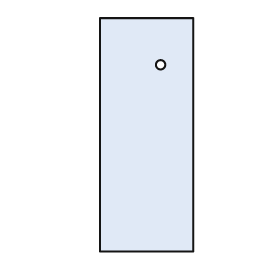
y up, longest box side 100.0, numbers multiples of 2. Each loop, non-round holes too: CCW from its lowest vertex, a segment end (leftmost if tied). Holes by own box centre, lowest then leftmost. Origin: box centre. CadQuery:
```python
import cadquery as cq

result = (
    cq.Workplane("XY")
    .moveTo(-20.0, -50.0)
    .lineTo(20.0, -50.0)
    .lineTo(20.0, 50.0)
    .lineTo(-20.0, 50.0)
    .close()
    .moveTo(6.0, 30.0)
    .circle(2.0)
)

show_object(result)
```